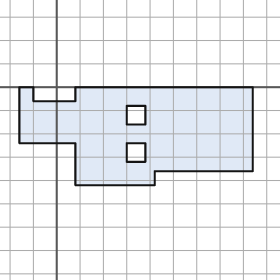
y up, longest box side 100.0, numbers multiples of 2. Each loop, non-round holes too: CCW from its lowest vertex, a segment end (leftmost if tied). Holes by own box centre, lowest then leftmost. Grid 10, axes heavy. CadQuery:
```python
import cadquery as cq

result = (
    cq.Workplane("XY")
    .moveTo(8.0, -42.0)
    .lineTo(42.0, -42.0)
    .lineTo(42.0, -36.0)
    .lineTo(84.0, -36.0)
    .lineTo(84.0, 0.0)
    .lineTo(8.0, 0.0)
    .lineTo(8.0, -6.0)
    .lineTo(-10.0, -6.0)
    .lineTo(-10.0, 0.0)
    .lineTo(-16.0, 0.0)
    .lineTo(-16.0, -24.0)
    .lineTo(8.0, -24.0)
    .close()
    .moveTo(30.0, -32.0)
    .lineTo(38.0, -32.0)
    .lineTo(38.0, -24.0)
    .lineTo(30.0, -24.0)
    .close()
    .moveTo(30.0, -16.0)
    .lineTo(38.0, -16.0)
    .lineTo(38.0, -8.0)
    .lineTo(30.0, -8.0)
    .close()
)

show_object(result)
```